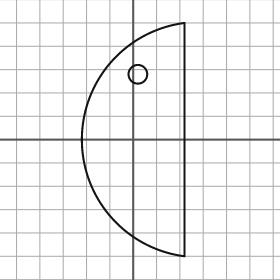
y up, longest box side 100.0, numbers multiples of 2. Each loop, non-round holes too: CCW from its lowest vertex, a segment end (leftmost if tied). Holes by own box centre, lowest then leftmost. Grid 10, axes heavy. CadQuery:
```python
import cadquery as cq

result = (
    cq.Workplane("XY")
    .moveTo(22.0, -50.0)
    .lineTo(22.0, 50.0)
    .threePointArc((-22.0, 0.0), (22.0, -50.0))
    .close()
    .moveTo(2.0, 28.0)
    .circle(4.0)
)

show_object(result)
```